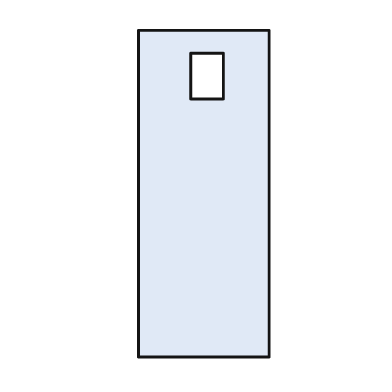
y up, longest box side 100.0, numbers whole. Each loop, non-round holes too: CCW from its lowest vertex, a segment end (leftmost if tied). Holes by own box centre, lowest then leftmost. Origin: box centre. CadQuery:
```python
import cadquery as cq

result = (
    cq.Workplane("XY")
    .moveTo(-20.0, -50.0)
    .lineTo(20.0, -50.0)
    .lineTo(20.0, 50.0)
    .lineTo(-20.0, 50.0)
    .close()
    .moveTo(-4.0, 29.0)
    .lineTo(6.0, 29.0)
    .lineTo(6.0, 43.0)
    .lineTo(-4.0, 43.0)
    .close()
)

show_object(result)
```